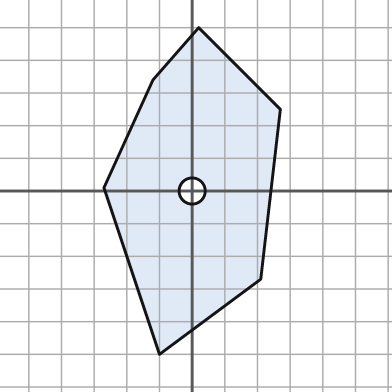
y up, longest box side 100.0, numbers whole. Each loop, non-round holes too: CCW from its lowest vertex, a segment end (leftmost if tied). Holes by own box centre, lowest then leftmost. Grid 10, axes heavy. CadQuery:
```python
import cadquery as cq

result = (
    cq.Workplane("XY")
    .moveTo(-10.0, -50.0)
    .lineTo(21.0, -27.0)
    .lineTo(27.0, 25.0)
    .lineTo(2.0, 50.0)
    .lineTo(-12.0, 34.0)
    .lineTo(-27.0, 1.0)
    .close()
    .moveTo(0.0, 0.0)
    .circle(4.0)
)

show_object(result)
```